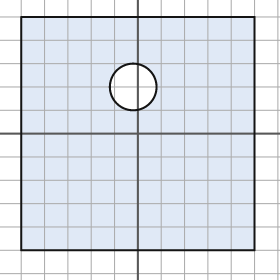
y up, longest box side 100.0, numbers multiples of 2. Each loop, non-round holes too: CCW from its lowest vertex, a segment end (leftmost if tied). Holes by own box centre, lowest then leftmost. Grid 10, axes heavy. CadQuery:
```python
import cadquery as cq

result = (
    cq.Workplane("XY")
    .moveTo(-50.0, -50.0)
    .lineTo(50.0, -50.0)
    .lineTo(50.0, 50.0)
    .lineTo(-50.0, 50.0)
    .close()
    .moveTo(-2.0, 20.0)
    .circle(10.0)
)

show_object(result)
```